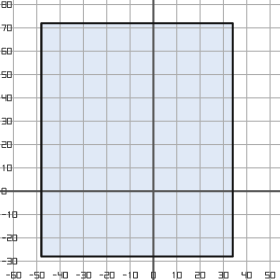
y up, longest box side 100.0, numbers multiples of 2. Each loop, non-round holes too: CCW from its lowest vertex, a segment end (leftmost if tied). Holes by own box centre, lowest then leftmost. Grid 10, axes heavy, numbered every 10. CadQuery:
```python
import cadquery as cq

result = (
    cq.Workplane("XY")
    .moveTo(-48.0, -28.0)
    .lineTo(34.0, -28.0)
    .lineTo(34.0, 72.0)
    .lineTo(-48.0, 72.0)
    .close()
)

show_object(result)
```